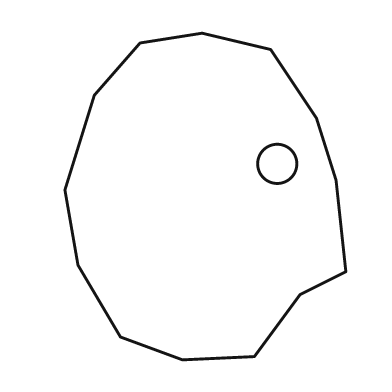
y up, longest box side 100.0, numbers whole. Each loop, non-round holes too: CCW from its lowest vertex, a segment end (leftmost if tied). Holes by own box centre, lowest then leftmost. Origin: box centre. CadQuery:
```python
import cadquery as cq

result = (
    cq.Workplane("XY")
    .moveTo(-7.0, -50.0)
    .lineTo(15.0, -49.0)
    .lineTo(29.0, -30.0)
    .lineTo(43.0, -23.0)
    .lineTo(40.0, 5.0)
    .lineTo(34.0, 24.0)
    .lineTo(20.0, 45.0)
    .lineTo(-1.0, 50.0)
    .lineTo(-20.0, 47.0)
    .lineTo(-34.0, 31.0)
    .lineTo(-43.0, 2.0)
    .lineTo(-39.0, -21.0)
    .lineTo(-26.0, -43.0)
    .close()
    .moveTo(22.0, 10.0)
    .circle(6.0)
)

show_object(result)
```